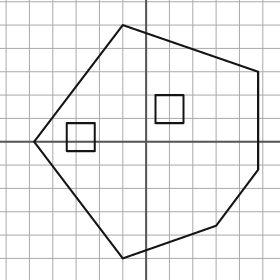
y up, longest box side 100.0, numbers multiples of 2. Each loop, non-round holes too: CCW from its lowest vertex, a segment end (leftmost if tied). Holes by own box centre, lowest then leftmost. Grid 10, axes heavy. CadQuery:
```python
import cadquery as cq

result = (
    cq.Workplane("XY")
    .moveTo(-10.0, -50.0)
    .lineTo(30.0, -36.0)
    .lineTo(48.0, -12.0)
    .lineTo(48.0, 30.0)
    .lineTo(-10.0, 50.0)
    .lineTo(-48.0, 0.0)
    .close()
    .moveTo(-34.0, -4.0)
    .lineTo(-22.0, -4.0)
    .lineTo(-22.0, 8.0)
    .lineTo(-34.0, 8.0)
    .close()
    .moveTo(4.0, 8.0)
    .lineTo(16.0, 8.0)
    .lineTo(16.0, 20.0)
    .lineTo(4.0, 20.0)
    .close()
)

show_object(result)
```